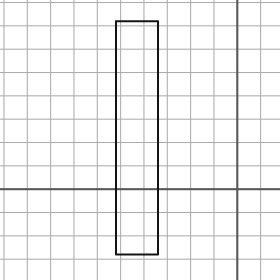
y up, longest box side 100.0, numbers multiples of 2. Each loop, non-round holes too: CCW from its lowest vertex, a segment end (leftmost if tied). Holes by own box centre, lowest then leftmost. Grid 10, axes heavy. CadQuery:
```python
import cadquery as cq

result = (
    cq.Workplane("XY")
    .moveTo(-52.0, -28.0)
    .lineTo(-34.0, -28.0)
    .lineTo(-34.0, 72.0)
    .lineTo(-52.0, 72.0)
    .close()
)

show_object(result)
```